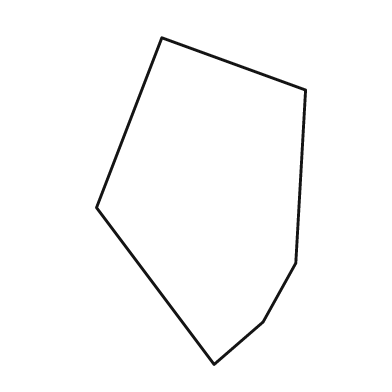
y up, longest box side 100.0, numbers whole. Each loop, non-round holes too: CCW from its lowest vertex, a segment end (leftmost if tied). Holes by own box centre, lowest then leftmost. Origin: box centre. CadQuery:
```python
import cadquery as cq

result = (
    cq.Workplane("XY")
    .moveTo(4.0, -50.0)
    .lineTo(19.0, -37.0)
    .lineTo(29.0, -19.0)
    .lineTo(32.0, 34.0)
    .lineTo(-12.0, 50.0)
    .lineTo(-32.0, -2.0)
    .close()
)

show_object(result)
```